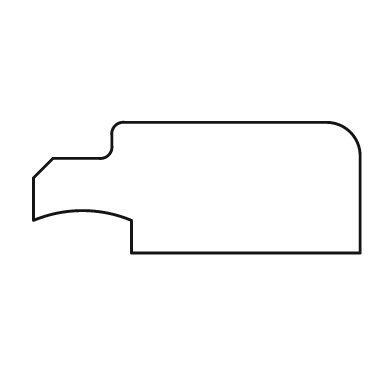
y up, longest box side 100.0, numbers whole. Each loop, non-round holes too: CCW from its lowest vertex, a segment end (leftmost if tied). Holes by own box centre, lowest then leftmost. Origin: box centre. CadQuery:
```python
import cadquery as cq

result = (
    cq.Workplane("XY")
    .moveTo(-20.0, -20.0)
    .lineTo(50.0, -20.0)
    .lineTo(50.0, 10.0)
    .threePointArc((47.0, 17.0), (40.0, 20.0))
    .lineTo(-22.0, 20.0)
    .threePointArc((-25.0, 19.0), (-26.0, 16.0))
    .lineTo(-26.0, 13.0)
    .threePointArc((-27.0, 10.0), (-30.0, 9.0))
    .lineTo(-44.0, 9.0)
    .lineTo(-50.0, 3.0)
    .lineTo(-50.0, -10.0)
    .threePointArc((-35.0, -7.0), (-20.0, -10.0))
    .close()
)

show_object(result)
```